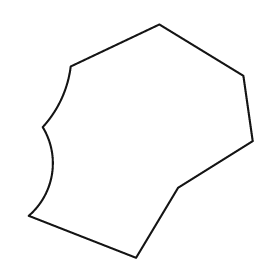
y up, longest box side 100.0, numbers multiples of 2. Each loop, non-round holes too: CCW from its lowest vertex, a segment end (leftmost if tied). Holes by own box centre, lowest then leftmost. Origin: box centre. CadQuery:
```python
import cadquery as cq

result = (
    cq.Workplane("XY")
    .moveTo(-2.0, -50.0)
    .lineTo(16.0, -20.0)
    .lineTo(48.0, 0.0)
    .lineTo(44.0, 28.0)
    .lineTo(8.0, 50.0)
    .lineTo(-30.0, 32.0)
    .threePointArc((-34.0, 18.0), (-42.0, 6.0))
    .threePointArc((-38.0, -14.0), (-48.0, -32.0))
    .close()
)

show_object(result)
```